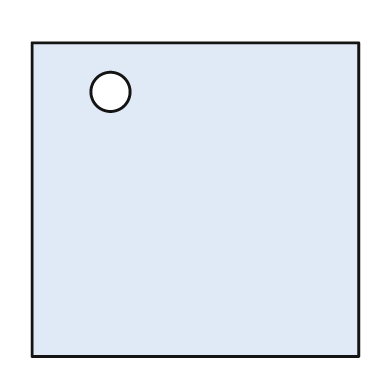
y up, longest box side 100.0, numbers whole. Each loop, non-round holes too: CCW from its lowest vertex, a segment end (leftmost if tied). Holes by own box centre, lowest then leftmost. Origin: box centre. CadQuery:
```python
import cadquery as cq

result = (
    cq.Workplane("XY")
    .moveTo(-50.0, -48.0)
    .lineTo(50.0, -48.0)
    .lineTo(50.0, 48.0)
    .lineTo(-50.0, 48.0)
    .close()
    .moveTo(-26.0, 33.0)
    .circle(6.0)
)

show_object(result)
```